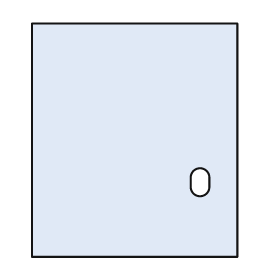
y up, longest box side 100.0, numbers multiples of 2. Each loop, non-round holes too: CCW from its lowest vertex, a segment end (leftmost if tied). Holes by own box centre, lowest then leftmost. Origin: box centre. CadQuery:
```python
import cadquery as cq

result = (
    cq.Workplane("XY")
    .moveTo(-44.0, -50.0)
    .lineTo(44.0, -50.0)
    .lineTo(44.0, 50.0)
    .lineTo(-44.0, 50.0)
    .close()
    .moveTo(24.0, -20.0)
    .threePointArc((28.0, -24.0), (32.0, -20.0))
    .lineTo(32.0, -16.0)
    .threePointArc((28.0, -12.0), (24.0, -16.0))
    .close()
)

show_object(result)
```